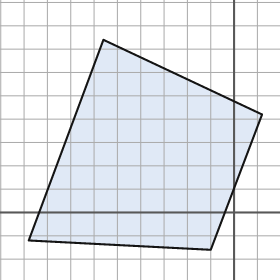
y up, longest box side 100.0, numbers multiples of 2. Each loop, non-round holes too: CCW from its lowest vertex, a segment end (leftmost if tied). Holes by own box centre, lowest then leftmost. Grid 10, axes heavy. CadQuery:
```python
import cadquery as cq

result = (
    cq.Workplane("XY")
    .moveTo(-10.0, -16.0)
    .lineTo(12.0, 42.0)
    .lineTo(-56.0, 74.0)
    .lineTo(-88.0, -12.0)
    .close()
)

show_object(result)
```